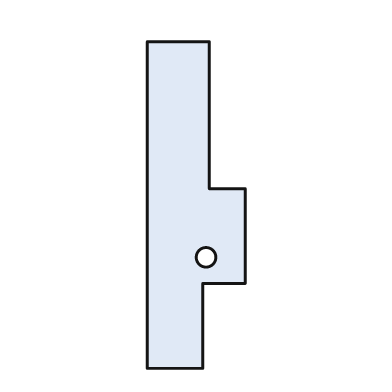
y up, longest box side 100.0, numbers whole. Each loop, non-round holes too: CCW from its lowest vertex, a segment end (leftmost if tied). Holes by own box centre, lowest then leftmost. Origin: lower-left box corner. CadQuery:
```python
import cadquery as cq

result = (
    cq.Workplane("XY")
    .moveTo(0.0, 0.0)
    .lineTo(17.0, 0.0)
    .lineTo(17.0, 26.0)
    .lineTo(30.0, 26.0)
    .lineTo(30.0, 55.0)
    .lineTo(19.0, 55.0)
    .lineTo(19.0, 100.0)
    .lineTo(0.0, 100.0)
    .close()
    .moveTo(18.0, 34.0)
    .circle(3.0)
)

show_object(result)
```